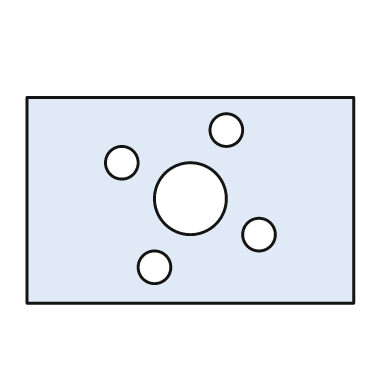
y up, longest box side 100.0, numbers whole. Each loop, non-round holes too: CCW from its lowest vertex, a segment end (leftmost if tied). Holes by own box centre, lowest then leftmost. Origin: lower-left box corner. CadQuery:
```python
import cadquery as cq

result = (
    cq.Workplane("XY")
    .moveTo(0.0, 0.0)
    .lineTo(100.0, 0.0)
    .lineTo(100.0, 63.0)
    .lineTo(0.0, 63.0)
    .close()
    .moveTo(39.0, 11.0)
    .circle(5.0)
    .moveTo(71.0, 21.0)
    .circle(5.0)
    .moveTo(50.0, 32.0)
    .circle(11.0)
    .moveTo(29.0, 43.0)
    .circle(5.0)
    .moveTo(61.0, 53.0)
    .circle(5.0)
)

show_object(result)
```